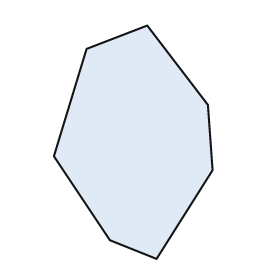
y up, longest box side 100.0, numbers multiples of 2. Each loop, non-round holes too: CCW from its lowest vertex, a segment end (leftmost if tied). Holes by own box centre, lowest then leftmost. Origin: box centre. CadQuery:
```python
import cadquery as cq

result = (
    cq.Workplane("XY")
    .moveTo(10.0, -50.0)
    .lineTo(34.0, -12.0)
    .lineTo(32.0, 16.0)
    .lineTo(6.0, 50.0)
    .lineTo(-20.0, 40.0)
    .lineTo(-34.0, -6.0)
    .lineTo(-10.0, -42.0)
    .close()
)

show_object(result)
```